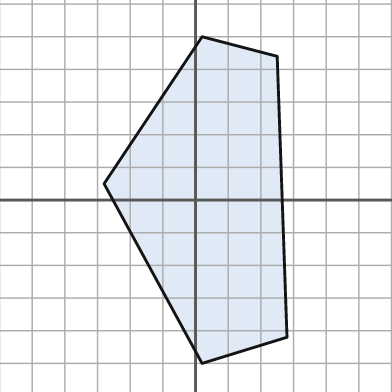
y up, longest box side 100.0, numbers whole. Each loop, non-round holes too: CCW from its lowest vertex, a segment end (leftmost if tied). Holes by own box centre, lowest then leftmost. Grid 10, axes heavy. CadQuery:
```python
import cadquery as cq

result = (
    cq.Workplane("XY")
    .moveTo(2.0, -50.0)
    .lineTo(28.0, -42.0)
    .lineTo(25.0, 44.0)
    .lineTo(2.0, 50.0)
    .lineTo(-28.0, 5.0)
    .close()
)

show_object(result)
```